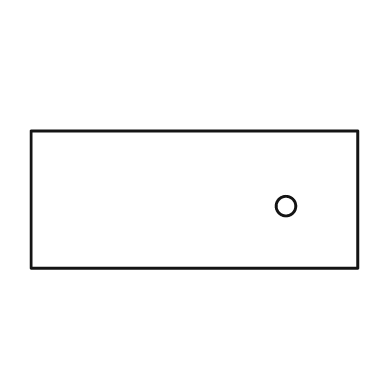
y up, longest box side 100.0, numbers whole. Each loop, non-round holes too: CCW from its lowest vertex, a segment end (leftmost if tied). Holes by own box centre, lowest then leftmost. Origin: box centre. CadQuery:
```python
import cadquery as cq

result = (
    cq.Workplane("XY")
    .moveTo(-50.0, -21.0)
    .lineTo(50.0, -21.0)
    .lineTo(50.0, 21.0)
    .lineTo(-50.0, 21.0)
    .close()
    .moveTo(28.0, -2.0)
    .circle(3.0)
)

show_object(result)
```